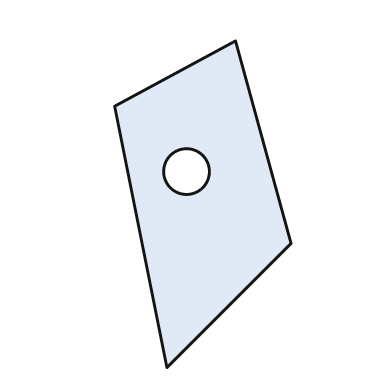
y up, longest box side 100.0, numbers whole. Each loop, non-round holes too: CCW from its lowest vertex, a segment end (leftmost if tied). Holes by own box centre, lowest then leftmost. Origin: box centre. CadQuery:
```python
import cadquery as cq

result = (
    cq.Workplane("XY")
    .moveTo(-11.0, -50.0)
    .lineTo(27.0, -12.0)
    .lineTo(10.0, 50.0)
    .lineTo(-27.0, 30.0)
    .close()
    .moveTo(-5.0, 10.0)
    .circle(7.0)
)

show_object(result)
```